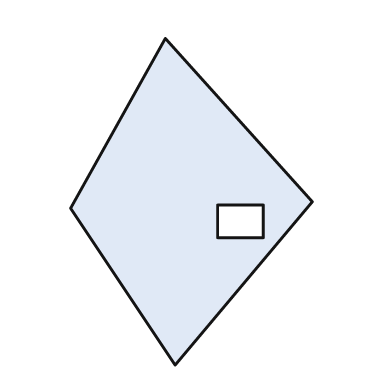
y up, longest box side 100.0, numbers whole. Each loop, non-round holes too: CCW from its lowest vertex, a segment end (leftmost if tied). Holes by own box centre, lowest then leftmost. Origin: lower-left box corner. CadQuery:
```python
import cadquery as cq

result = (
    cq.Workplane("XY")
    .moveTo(32.0, 0.0)
    .lineTo(74.0, 50.0)
    .lineTo(29.0, 100.0)
    .lineTo(0.0, 48.0)
    .close()
    .moveTo(45.0, 39.0)
    .lineTo(59.0, 39.0)
    .lineTo(59.0, 49.0)
    .lineTo(45.0, 49.0)
    .close()
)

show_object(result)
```